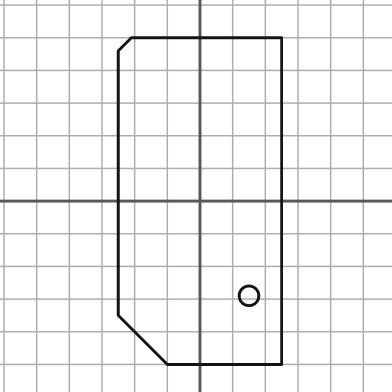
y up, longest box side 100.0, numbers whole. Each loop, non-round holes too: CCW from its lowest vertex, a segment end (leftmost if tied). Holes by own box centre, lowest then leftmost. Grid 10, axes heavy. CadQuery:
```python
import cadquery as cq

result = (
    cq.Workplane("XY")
    .moveTo(-10.0, -50.0)
    .lineTo(25.0, -50.0)
    .lineTo(25.0, 50.0)
    .lineTo(-21.0, 50.0)
    .lineTo(-25.0, 46.0)
    .lineTo(-25.0, -35.0)
    .close()
    .moveTo(15.0, -29.0)
    .circle(3.0)
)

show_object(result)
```